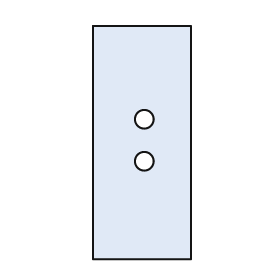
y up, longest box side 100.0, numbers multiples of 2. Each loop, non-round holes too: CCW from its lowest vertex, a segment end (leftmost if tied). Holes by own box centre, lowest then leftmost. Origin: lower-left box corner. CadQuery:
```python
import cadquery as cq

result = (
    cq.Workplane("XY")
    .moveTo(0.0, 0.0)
    .lineTo(42.0, 0.0)
    .lineTo(42.0, 100.0)
    .lineTo(0.0, 100.0)
    .close()
    .moveTo(22.0, 42.0)
    .circle(4.0)
    .moveTo(22.0, 60.0)
    .circle(4.0)
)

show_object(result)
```